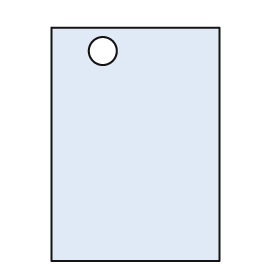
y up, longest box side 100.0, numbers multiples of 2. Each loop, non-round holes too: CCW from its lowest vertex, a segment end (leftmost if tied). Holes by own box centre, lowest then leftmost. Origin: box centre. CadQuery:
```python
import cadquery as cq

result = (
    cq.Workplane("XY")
    .moveTo(-36.0, -50.0)
    .lineTo(36.0, -50.0)
    .lineTo(36.0, 50.0)
    .lineTo(-36.0, 50.0)
    .close()
    .moveTo(-14.0, 40.0)
    .circle(6.0)
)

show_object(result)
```